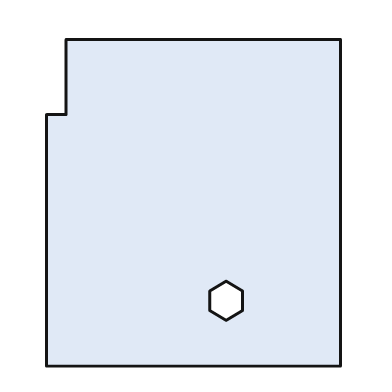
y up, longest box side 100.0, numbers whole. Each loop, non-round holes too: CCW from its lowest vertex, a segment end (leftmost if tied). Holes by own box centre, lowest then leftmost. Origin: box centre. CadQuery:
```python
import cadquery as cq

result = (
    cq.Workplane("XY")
    .moveTo(-45.0, -50.0)
    .lineTo(45.0, -50.0)
    .lineTo(45.0, 50.0)
    .lineTo(-39.0, 50.0)
    .lineTo(-39.0, 27.0)
    .lineTo(-45.0, 27.0)
    .close()
    .moveTo(10.0, -36.0)
    .lineTo(15.0, -33.0)
    .lineTo(15.0, -27.0)
    .lineTo(10.0, -24.0)
    .lineTo(5.0, -27.0)
    .lineTo(5.0, -33.0)
    .close()
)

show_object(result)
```